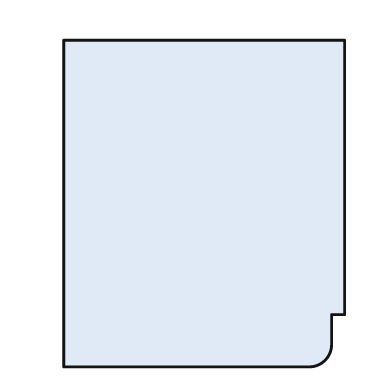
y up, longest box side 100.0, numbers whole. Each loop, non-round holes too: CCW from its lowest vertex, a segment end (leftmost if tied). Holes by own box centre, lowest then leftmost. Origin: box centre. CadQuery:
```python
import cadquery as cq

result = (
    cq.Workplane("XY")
    .moveTo(-43.0, -50.0)
    .lineTo(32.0, -50.0)
    .threePointArc((37.0, -48.0), (39.0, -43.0))
    .lineTo(39.0, -34.0)
    .lineTo(43.0, -34.0)
    .lineTo(43.0, 50.0)
    .lineTo(-43.0, 50.0)
    .close()
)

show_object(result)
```